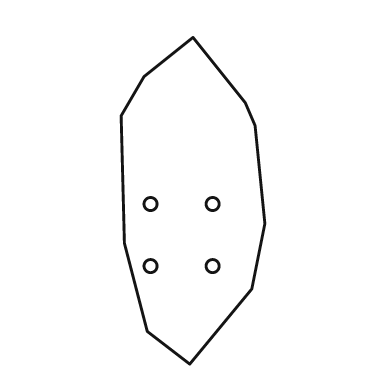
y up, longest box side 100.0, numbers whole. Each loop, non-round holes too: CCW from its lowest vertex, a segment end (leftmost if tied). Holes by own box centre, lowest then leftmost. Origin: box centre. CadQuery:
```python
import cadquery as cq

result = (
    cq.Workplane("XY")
    .moveTo(-1.0, -50.0)
    .lineTo(18.0, -27.0)
    .lineTo(22.0, -7.0)
    .lineTo(19.0, 23.0)
    .lineTo(16.0, 30.0)
    .lineTo(0.0, 50.0)
    .lineTo(-15.0, 38.0)
    .lineTo(-22.0, 26.0)
    .lineTo(-21.0, -13.0)
    .lineTo(-14.0, -40.0)
    .close()
    .moveTo(-13.0, -20.0)
    .circle(2.0)
    .moveTo(6.0, -20.0)
    .circle(2.0)
    .moveTo(-13.0, -1.0)
    .circle(2.0)
    .moveTo(6.0, -1.0)
    .circle(2.0)
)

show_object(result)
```